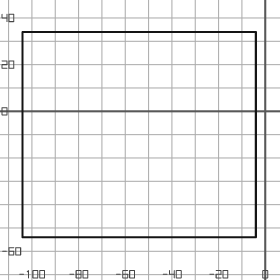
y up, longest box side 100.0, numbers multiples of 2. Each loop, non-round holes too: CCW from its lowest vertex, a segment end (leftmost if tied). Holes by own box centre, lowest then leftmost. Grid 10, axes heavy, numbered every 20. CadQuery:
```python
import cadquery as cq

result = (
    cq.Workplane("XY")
    .moveTo(-104.0, -54.0)
    .lineTo(-4.0, -54.0)
    .lineTo(-4.0, 34.0)
    .lineTo(-104.0, 34.0)
    .close()
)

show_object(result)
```